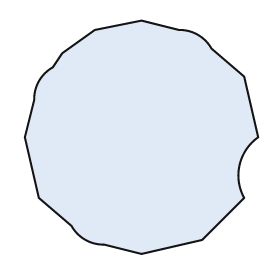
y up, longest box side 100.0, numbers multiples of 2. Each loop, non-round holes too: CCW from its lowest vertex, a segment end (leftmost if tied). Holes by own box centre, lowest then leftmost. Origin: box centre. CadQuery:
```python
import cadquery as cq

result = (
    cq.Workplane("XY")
    .moveTo(0.0, -50.0)
    .lineTo(26.0, -44.0)
    .lineTo(44.0, -26.0)
    .threePointArc((42.0, -12.0), (50.0, 0.0))
    .lineTo(44.0, 26.0)
    .lineTo(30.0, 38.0)
    .threePointArc((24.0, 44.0), (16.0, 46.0))
    .lineTo(0.0, 50.0)
    .lineTo(-20.0, 46.0)
    .lineTo(-34.0, 36.0)
    .lineTo(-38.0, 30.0)
    .threePointArc((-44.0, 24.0), (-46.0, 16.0))
    .lineTo(-50.0, 0.0)
    .lineTo(-44.0, -26.0)
    .lineTo(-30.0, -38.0)
    .threePointArc((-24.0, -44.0), (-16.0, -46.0))
    .close()
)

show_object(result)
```